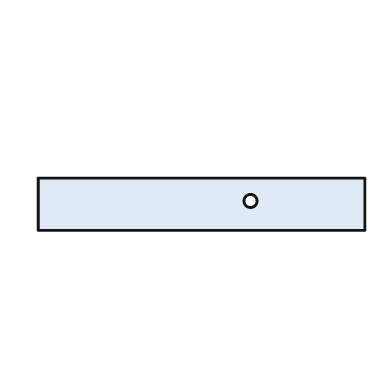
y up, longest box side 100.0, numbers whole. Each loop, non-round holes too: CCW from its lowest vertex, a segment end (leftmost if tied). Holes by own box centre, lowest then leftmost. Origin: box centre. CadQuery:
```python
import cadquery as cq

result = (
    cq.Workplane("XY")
    .moveTo(-50.0, -8.0)
    .lineTo(50.0, -8.0)
    .lineTo(50.0, 8.0)
    .lineTo(-50.0, 8.0)
    .close()
    .moveTo(15.0, 1.0)
    .circle(2.0)
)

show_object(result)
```